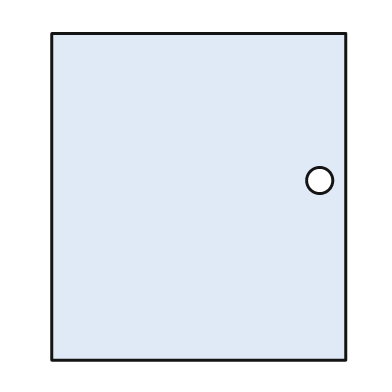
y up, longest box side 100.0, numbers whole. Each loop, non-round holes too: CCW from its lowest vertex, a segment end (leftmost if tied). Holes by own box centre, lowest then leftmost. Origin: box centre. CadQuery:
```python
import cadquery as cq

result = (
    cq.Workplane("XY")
    .moveTo(-45.0, -50.0)
    .lineTo(45.0, -50.0)
    .lineTo(45.0, 50.0)
    .lineTo(-45.0, 50.0)
    .close()
    .moveTo(37.0, 5.0)
    .circle(4.0)
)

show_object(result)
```